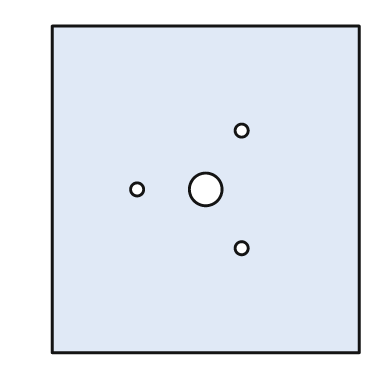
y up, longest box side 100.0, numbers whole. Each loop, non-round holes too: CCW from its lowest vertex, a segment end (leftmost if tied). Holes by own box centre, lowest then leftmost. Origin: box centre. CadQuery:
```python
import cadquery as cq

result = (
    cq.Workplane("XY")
    .moveTo(-47.0, -50.0)
    .lineTo(47.0, -50.0)
    .lineTo(47.0, 50.0)
    .lineTo(-47.0, 50.0)
    .close()
    .moveTo(11.0, -18.0)
    .circle(2.0)
    .moveTo(-21.0, 0.0)
    .circle(2.0)
    .moveTo(0.0, 0.0)
    .circle(5.0)
    .moveTo(11.0, 18.0)
    .circle(2.0)
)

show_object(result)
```